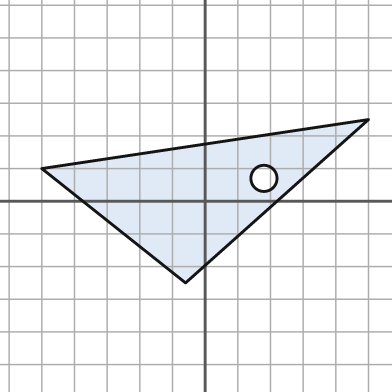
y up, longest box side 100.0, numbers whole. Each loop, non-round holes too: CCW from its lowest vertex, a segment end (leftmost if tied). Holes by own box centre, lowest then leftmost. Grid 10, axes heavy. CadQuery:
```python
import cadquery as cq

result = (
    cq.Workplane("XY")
    .moveTo(-6.0, -25.0)
    .lineTo(50.0, 25.0)
    .lineTo(-50.0, 10.0)
    .close()
    .moveTo(18.0, 7.0)
    .circle(4.0)
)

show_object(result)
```